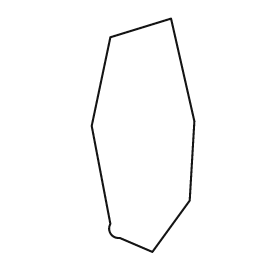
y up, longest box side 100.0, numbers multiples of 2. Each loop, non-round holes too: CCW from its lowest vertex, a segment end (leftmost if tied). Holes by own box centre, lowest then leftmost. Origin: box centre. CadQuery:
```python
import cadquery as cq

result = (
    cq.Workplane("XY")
    .moveTo(4.0, -50.0)
    .lineTo(20.0, -28.0)
    .lineTo(22.0, 6.0)
    .lineTo(12.0, 50.0)
    .lineTo(-14.0, 42.0)
    .lineTo(-22.0, 4.0)
    .lineTo(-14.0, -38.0)
    .threePointArc((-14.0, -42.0), (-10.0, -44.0))
    .close()
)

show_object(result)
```